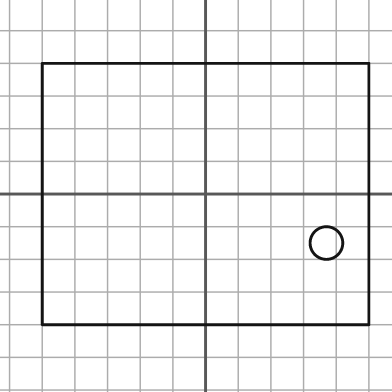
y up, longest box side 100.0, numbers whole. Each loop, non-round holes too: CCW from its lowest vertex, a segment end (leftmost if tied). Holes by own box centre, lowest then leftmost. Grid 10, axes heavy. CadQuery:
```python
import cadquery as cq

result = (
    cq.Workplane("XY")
    .moveTo(-50.0, -40.0)
    .lineTo(50.0, -40.0)
    .lineTo(50.0, 40.0)
    .lineTo(-50.0, 40.0)
    .close()
    .moveTo(37.0, -15.0)
    .circle(5.0)
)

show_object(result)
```